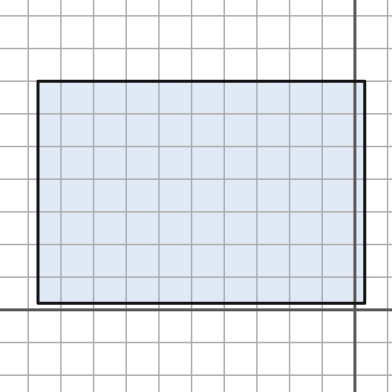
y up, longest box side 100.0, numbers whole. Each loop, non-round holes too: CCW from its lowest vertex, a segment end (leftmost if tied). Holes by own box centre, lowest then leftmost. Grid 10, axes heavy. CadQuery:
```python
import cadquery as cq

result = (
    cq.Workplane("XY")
    .moveTo(-97.0, 2.0)
    .lineTo(3.0, 2.0)
    .lineTo(3.0, 70.0)
    .lineTo(-97.0, 70.0)
    .close()
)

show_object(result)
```